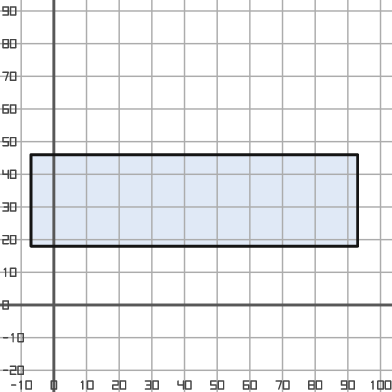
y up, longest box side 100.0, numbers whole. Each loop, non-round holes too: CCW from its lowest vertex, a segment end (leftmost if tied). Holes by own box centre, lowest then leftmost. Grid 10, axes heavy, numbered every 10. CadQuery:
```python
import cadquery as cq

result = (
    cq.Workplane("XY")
    .moveTo(-7.0, 18.0)
    .lineTo(93.0, 18.0)
    .lineTo(93.0, 46.0)
    .lineTo(-7.0, 46.0)
    .close()
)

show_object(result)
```